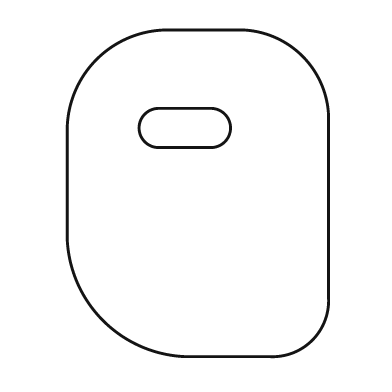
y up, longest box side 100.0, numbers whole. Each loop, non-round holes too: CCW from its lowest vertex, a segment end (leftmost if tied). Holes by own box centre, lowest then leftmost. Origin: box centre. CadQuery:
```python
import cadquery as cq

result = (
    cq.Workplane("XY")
    .moveTo(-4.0, -50.0)
    .lineTo(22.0, -50.0)
    .threePointArc((35.0, -45.0), (40.0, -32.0))
    .lineTo(40.0, 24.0)
    .threePointArc((32.0, 42.0), (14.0, 50.0))
    .lineTo(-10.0, 50.0)
    .threePointArc((-31.0, 41.0), (-40.0, 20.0))
    .lineTo(-40.0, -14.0)
    .threePointArc((-29.0, -39.0), (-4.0, -50.0))
    .close()
    .moveTo(-12.0, 14.0)
    .lineTo(4.0, 14.0)
    .threePointArc((10.0, 20.0), (4.0, 26.0))
    .lineTo(-12.0, 26.0)
    .threePointArc((-18.0, 20.0), (-12.0, 14.0))
    .close()
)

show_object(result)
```